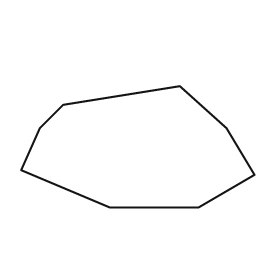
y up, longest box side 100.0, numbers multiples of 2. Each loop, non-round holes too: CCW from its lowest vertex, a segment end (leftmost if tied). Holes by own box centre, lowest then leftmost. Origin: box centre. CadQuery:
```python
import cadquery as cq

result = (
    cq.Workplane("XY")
    .moveTo(-12.0, -26.0)
    .lineTo(26.0, -26.0)
    .lineTo(50.0, -12.0)
    .lineTo(38.0, 8.0)
    .lineTo(18.0, 26.0)
    .lineTo(-32.0, 18.0)
    .lineTo(-42.0, 8.0)
    .lineTo(-50.0, -10.0)
    .close()
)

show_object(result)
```